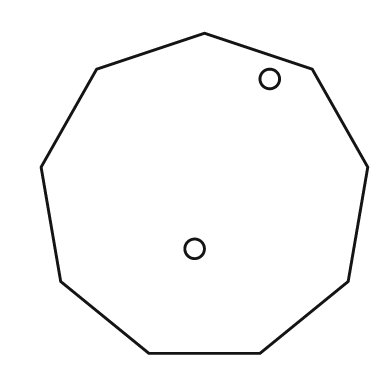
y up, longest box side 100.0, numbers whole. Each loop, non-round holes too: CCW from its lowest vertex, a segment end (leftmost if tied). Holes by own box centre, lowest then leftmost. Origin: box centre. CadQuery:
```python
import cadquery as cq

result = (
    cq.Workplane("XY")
    .moveTo(-17.0, -49.0)
    .lineTo(17.0, -49.0)
    .lineTo(44.0, -27.0)
    .lineTo(50.0, 8.0)
    .lineTo(33.0, 38.0)
    .lineTo(0.0, 49.0)
    .lineTo(-33.0, 38.0)
    .lineTo(-50.0, 8.0)
    .lineTo(-44.0, -27.0)
    .close()
    .moveTo(-3.0, -17.0)
    .circle(3.0)
    .moveTo(20.0, 35.0)
    .circle(3.0)
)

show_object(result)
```